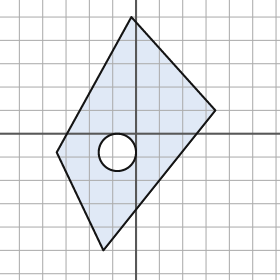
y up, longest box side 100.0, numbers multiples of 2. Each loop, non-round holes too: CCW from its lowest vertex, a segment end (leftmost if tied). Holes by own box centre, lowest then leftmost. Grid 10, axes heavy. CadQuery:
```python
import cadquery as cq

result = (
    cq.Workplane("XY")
    .moveTo(-14.0, -50.0)
    .lineTo(34.0, 10.0)
    .lineTo(-2.0, 50.0)
    .lineTo(-34.0, -8.0)
    .close()
    .moveTo(-8.0, -8.0)
    .circle(8.0)
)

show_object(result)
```